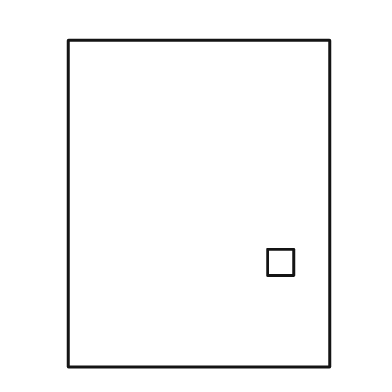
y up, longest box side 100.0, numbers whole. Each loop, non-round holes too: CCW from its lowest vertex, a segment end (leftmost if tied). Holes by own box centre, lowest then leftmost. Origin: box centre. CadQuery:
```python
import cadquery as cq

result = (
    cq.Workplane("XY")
    .moveTo(-40.0, -50.0)
    .lineTo(40.0, -50.0)
    .lineTo(40.0, 50.0)
    .lineTo(-40.0, 50.0)
    .close()
    .moveTo(21.0, -22.0)
    .lineTo(29.0, -22.0)
    .lineTo(29.0, -14.0)
    .lineTo(21.0, -14.0)
    .close()
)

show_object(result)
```